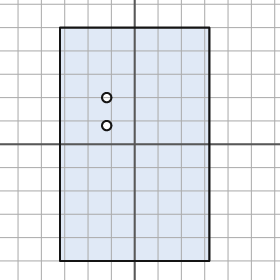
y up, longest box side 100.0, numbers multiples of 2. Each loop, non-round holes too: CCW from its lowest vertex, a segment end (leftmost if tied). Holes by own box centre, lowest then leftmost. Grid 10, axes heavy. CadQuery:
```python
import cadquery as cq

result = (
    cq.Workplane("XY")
    .moveTo(-32.0, -50.0)
    .lineTo(32.0, -50.0)
    .lineTo(32.0, 50.0)
    .lineTo(-32.0, 50.0)
    .close()
    .moveTo(-12.0, 8.0)
    .circle(2.0)
    .moveTo(-12.0, 20.0)
    .circle(2.0)
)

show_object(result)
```